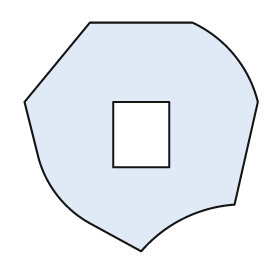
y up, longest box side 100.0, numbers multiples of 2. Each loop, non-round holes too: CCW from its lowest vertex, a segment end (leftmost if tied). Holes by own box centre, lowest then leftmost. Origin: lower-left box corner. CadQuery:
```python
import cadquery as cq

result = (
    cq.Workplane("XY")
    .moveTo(50.0, 0.0)
    .threePointArc((68.0, 14.0), (90.0, 20.0))
    .lineTo(100.0, 64.0)
    .threePointArc((90.0, 84.0), (72.0, 98.0))
    .lineTo(28.0, 98.0)
    .lineTo(0.0, 64.0)
    .lineTo(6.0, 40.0)
    .threePointArc((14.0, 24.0), (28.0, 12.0))
    .close()
    .moveTo(38.0, 36.0)
    .lineTo(62.0, 36.0)
    .lineTo(62.0, 64.0)
    .lineTo(38.0, 64.0)
    .close()
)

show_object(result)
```